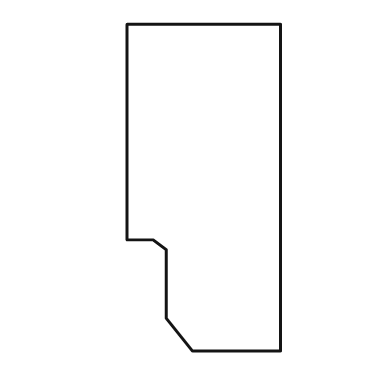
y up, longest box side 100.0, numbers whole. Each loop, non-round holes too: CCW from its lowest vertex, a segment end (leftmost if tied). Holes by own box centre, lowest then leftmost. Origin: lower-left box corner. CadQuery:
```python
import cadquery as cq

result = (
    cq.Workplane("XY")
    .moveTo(20.0, 0.0)
    .lineTo(47.0, 0.0)
    .lineTo(47.0, 100.0)
    .lineTo(0.0, 100.0)
    .lineTo(0.0, 34.0)
    .lineTo(8.0, 34.0)
    .lineTo(12.0, 31.0)
    .lineTo(12.0, 10.0)
    .close()
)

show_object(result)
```